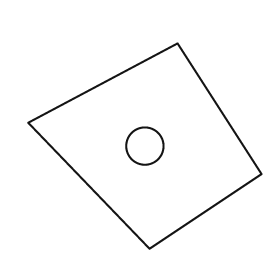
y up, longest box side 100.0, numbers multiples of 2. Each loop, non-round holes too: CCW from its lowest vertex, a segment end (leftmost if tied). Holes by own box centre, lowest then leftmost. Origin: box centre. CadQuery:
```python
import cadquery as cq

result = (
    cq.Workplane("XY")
    .moveTo(2.0, -44.0)
    .lineTo(50.0, -12.0)
    .lineTo(14.0, 44.0)
    .lineTo(-50.0, 10.0)
    .close()
    .moveTo(0.0, 0.0)
    .circle(8.0)
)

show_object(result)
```